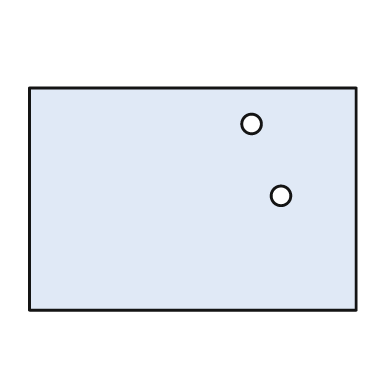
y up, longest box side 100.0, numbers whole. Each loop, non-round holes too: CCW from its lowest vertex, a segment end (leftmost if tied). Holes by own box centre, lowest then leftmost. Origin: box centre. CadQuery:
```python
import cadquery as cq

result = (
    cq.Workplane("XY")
    .moveTo(-50.0, -34.0)
    .lineTo(50.0, -34.0)
    .lineTo(50.0, 34.0)
    .lineTo(-50.0, 34.0)
    .close()
    .moveTo(27.0, 1.0)
    .circle(3.0)
    .moveTo(18.0, 23.0)
    .circle(3.0)
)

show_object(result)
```